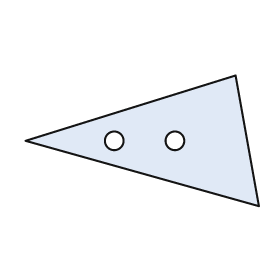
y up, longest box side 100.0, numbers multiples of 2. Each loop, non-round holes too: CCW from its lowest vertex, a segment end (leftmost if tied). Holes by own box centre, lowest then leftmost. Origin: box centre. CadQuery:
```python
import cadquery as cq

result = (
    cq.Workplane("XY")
    .moveTo(50.0, -28.0)
    .lineTo(40.0, 28.0)
    .lineTo(-50.0, 0.0)
    .close()
    .moveTo(-12.0, 0.0)
    .circle(4.0)
    .moveTo(14.0, 0.0)
    .circle(4.0)
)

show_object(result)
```